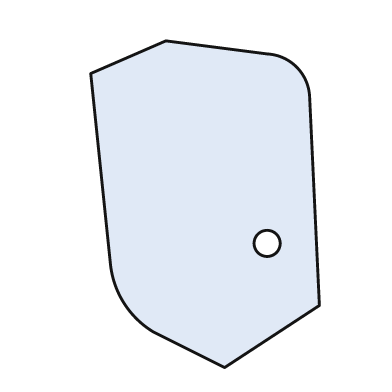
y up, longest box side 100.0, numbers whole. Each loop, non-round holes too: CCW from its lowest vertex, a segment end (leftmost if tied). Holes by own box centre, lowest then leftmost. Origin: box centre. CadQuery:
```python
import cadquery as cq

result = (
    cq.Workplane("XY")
    .moveTo(6.0, -50.0)
    .lineTo(35.0, -31.0)
    .lineTo(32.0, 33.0)
    .threePointArc((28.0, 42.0), (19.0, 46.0))
    .lineTo(-12.0, 50.0)
    .lineTo(-35.0, 40.0)
    .lineTo(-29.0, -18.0)
    .threePointArc((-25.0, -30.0), (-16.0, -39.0))
    .close()
    .moveTo(19.0, -12.0)
    .circle(4.0)
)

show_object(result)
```